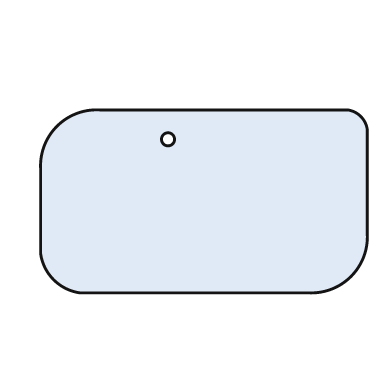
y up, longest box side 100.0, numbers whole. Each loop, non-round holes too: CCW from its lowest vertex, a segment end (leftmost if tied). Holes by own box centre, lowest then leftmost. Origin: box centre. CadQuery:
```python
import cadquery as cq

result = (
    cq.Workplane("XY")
    .moveTo(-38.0, -28.0)
    .lineTo(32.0, -28.0)
    .threePointArc((45.0, -23.0), (50.0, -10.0))
    .lineTo(50.0, 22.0)
    .threePointArc((48.0, 26.0), (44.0, 28.0))
    .lineTo(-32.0, 28.0)
    .threePointArc((-45.0, 23.0), (-50.0, 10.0))
    .lineTo(-50.0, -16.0)
    .threePointArc((-46.0, -24.0), (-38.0, -28.0))
    .close()
    .moveTo(-11.0, 19.0)
    .circle(2.0)
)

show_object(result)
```